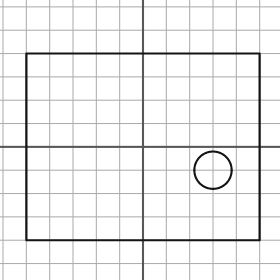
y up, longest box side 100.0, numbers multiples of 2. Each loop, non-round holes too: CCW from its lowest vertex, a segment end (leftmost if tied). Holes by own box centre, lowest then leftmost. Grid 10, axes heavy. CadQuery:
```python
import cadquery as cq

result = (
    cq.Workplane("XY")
    .moveTo(-50.0, -40.0)
    .lineTo(50.0, -40.0)
    .lineTo(50.0, 40.0)
    .lineTo(-50.0, 40.0)
    .close()
    .moveTo(30.0, -10.0)
    .circle(8.0)
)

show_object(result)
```